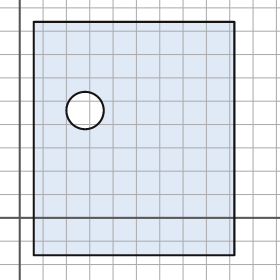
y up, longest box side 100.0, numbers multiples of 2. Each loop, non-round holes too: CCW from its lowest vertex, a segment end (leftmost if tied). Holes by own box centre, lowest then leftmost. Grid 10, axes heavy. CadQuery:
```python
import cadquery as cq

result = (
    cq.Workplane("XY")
    .moveTo(6.0, -16.0)
    .lineTo(92.0, -16.0)
    .lineTo(92.0, 84.0)
    .lineTo(6.0, 84.0)
    .close()
    .moveTo(28.0, 46.0)
    .circle(8.0)
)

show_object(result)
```